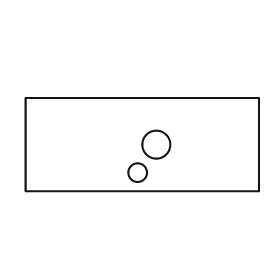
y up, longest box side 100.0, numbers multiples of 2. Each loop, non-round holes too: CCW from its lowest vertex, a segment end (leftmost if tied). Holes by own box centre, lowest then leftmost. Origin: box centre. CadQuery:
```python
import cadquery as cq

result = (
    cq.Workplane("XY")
    .moveTo(-50.0, -20.0)
    .lineTo(50.0, -20.0)
    .lineTo(50.0, 20.0)
    .lineTo(-50.0, 20.0)
    .close()
    .moveTo(-2.0, -12.0)
    .circle(4.0)
    .moveTo(6.0, 0.0)
    .circle(6.0)
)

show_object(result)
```